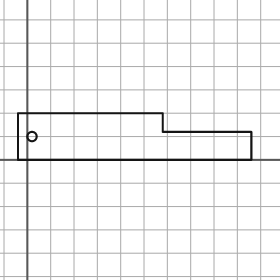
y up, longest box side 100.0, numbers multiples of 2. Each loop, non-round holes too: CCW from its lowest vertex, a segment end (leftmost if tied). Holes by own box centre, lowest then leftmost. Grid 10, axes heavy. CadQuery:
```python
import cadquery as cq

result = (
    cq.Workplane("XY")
    .moveTo(-4.0, 0.0)
    .lineTo(96.0, 0.0)
    .lineTo(96.0, 12.0)
    .lineTo(58.0, 12.0)
    .lineTo(58.0, 20.0)
    .lineTo(-4.0, 20.0)
    .close()
    .moveTo(2.0, 10.0)
    .circle(2.0)
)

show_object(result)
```